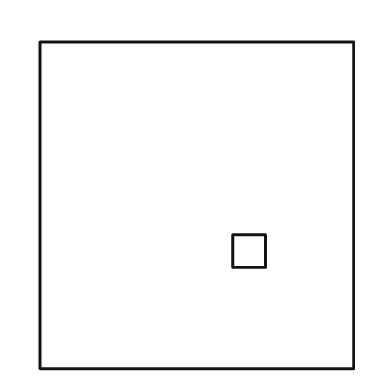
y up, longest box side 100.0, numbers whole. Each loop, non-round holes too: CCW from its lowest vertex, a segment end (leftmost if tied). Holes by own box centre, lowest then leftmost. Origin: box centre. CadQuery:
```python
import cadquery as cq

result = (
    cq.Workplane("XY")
    .moveTo(-48.0, -50.0)
    .lineTo(48.0, -50.0)
    .lineTo(48.0, 50.0)
    .lineTo(-48.0, 50.0)
    .close()
    .moveTo(11.0, -19.0)
    .lineTo(21.0, -19.0)
    .lineTo(21.0, -9.0)
    .lineTo(11.0, -9.0)
    .close()
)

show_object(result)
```